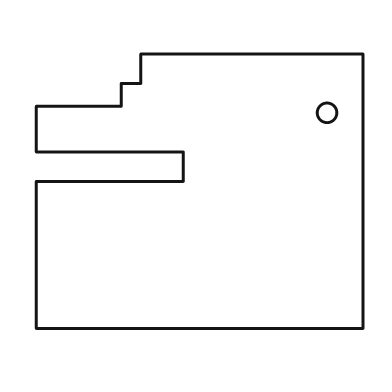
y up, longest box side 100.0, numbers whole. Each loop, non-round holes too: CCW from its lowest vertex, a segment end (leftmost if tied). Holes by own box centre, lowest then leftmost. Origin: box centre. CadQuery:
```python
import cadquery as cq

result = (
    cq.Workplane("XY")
    .moveTo(-50.0, -42.0)
    .lineTo(50.0, -42.0)
    .lineTo(50.0, 42.0)
    .lineTo(-18.0, 42.0)
    .lineTo(-18.0, 33.0)
    .lineTo(-24.0, 33.0)
    .lineTo(-24.0, 26.0)
    .lineTo(-50.0, 26.0)
    .lineTo(-50.0, 12.0)
    .lineTo(-5.0, 12.0)
    .lineTo(-5.0, 3.0)
    .lineTo(-50.0, 3.0)
    .close()
    .moveTo(39.0, 24.0)
    .circle(3.0)
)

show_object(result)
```